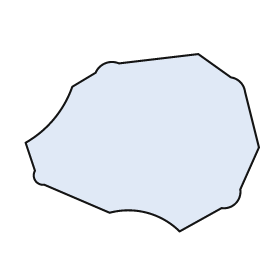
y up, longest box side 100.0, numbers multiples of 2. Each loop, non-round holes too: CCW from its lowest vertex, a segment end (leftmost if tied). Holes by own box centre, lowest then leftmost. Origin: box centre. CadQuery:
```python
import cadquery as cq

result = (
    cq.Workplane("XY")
    .moveTo(16.0, -38.0)
    .lineTo(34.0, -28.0)
    .threePointArc((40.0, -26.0), (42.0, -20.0))
    .lineTo(50.0, -2.0)
    .lineTo(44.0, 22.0)
    .threePointArc((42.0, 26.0), (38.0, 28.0))
    .lineTo(24.0, 38.0)
    .lineTo(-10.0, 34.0)
    .threePointArc((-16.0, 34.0), (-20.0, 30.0))
    .lineTo(-30.0, 24.0)
    .threePointArc((-38.0, 10.0), (-50.0, 0.0))
    .lineTo(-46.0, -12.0)
    .threePointArc((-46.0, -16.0), (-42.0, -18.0))
    .lineTo(-14.0, -30.0)
    .threePointArc((2.0, -30.0), (16.0, -38.0))
    .close()
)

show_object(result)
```